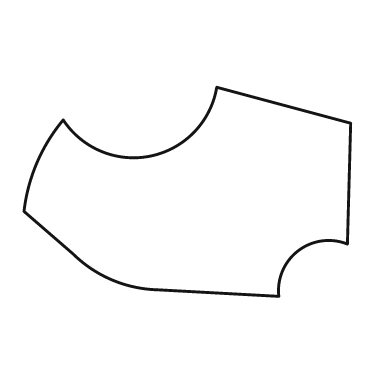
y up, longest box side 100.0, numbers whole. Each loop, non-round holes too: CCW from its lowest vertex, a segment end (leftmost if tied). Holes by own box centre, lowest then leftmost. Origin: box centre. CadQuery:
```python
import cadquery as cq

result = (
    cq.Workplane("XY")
    .moveTo(28.0, -32.0)
    .threePointArc((34.0, -18.0), (49.0, -16.0))
    .lineTo(50.0, 21.0)
    .lineTo(9.0, 32.0)
    .threePointArc((-11.0, 11.0), (-38.0, 22.0))
    .threePointArc((-46.0, 9.0), (-50.0, -6.0))
    .lineTo(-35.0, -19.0)
    .threePointArc((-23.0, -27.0), (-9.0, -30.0))
    .close()
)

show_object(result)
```